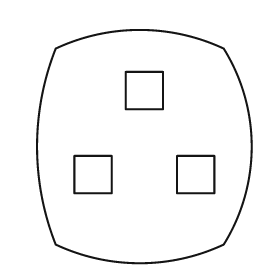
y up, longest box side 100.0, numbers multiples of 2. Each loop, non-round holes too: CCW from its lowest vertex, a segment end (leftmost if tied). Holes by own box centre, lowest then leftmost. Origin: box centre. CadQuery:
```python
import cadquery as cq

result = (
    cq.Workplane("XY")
    .moveTo(-38.0, -42.0)
    .threePointArc((-2.0, -50.0), (34.0, -42.0))
    .threePointArc((46.0, 0.0), (34.0, 42.0))
    .threePointArc((-2.0, 50.0), (-38.0, 42.0))
    .threePointArc((-46.0, 0.0), (-38.0, -42.0))
    .close()
    .moveTo(-30.0, -20.0)
    .lineTo(-14.0, -20.0)
    .lineTo(-14.0, -4.0)
    .lineTo(-30.0, -4.0)
    .close()
    .moveTo(14.0, -20.0)
    .lineTo(30.0, -20.0)
    .lineTo(30.0, -4.0)
    .lineTo(14.0, -4.0)
    .close()
    .moveTo(-8.0, 16.0)
    .lineTo(8.0, 16.0)
    .lineTo(8.0, 32.0)
    .lineTo(-8.0, 32.0)
    .close()
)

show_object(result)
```